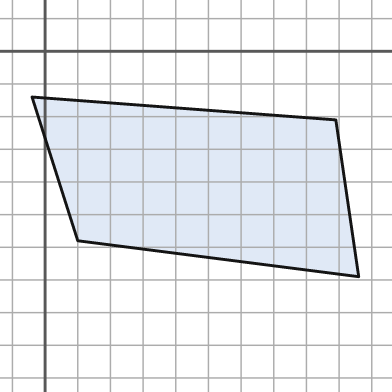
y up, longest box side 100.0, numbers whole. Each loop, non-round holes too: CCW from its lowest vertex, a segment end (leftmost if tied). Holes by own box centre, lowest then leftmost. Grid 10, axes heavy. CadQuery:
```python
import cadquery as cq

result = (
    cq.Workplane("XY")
    .moveTo(96.0, -69.0)
    .lineTo(89.0, -21.0)
    .lineTo(-4.0, -14.0)
    .lineTo(10.0, -58.0)
    .close()
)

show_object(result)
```